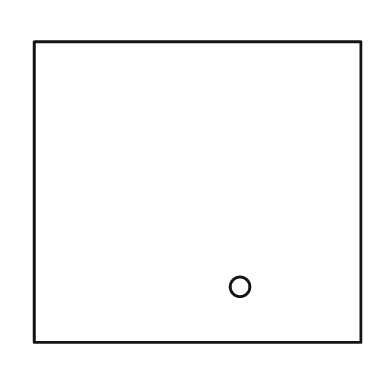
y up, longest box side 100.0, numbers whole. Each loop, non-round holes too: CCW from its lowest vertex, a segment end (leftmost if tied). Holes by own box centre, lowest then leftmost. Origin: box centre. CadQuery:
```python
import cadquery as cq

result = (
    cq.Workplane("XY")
    .moveTo(-50.0, -46.0)
    .lineTo(50.0, -46.0)
    .lineTo(50.0, 46.0)
    .lineTo(-50.0, 46.0)
    .close()
    .moveTo(13.0, -29.0)
    .circle(3.0)
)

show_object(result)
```